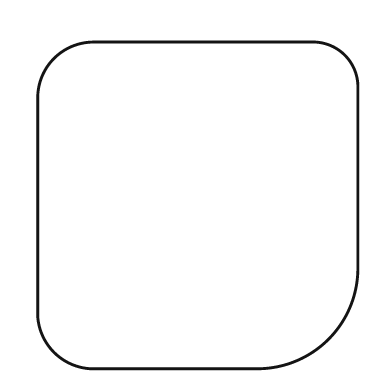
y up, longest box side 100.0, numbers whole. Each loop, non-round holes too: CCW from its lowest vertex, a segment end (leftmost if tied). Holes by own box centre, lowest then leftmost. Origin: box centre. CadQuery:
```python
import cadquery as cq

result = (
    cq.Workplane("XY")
    .moveTo(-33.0, -50.0)
    .lineTo(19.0, -50.0)
    .threePointArc((40.0, -41.0), (49.0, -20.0))
    .lineTo(49.0, 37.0)
    .threePointArc((45.0, 46.0), (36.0, 50.0))
    .lineTo(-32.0, 50.0)
    .threePointArc((-44.0, 45.0), (-49.0, 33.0))
    .lineTo(-49.0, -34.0)
    .threePointArc((-44.0, -45.0), (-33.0, -50.0))
    .close()
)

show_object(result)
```